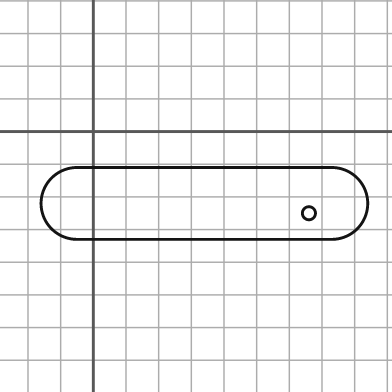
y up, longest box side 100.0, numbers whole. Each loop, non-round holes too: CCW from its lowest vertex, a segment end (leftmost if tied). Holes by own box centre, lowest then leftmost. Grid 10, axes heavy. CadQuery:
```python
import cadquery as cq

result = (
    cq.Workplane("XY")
    .moveTo(-5.0, -33.0)
    .lineTo(73.0, -33.0)
    .threePointArc((84.0, -22.0), (73.0, -11.0))
    .lineTo(-5.0, -11.0)
    .threePointArc((-16.0, -22.0), (-5.0, -33.0))
    .close()
    .moveTo(66.0, -25.0)
    .circle(2.0)
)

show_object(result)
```